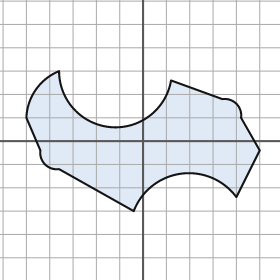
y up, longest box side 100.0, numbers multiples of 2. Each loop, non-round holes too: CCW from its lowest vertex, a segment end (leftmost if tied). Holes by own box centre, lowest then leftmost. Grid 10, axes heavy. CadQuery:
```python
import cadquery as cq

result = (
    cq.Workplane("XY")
    .moveTo(-4.0, -30.0)
    .threePointArc((16.0, -14.0), (40.0, -24.0))
    .lineTo(50.0, -4.0)
    .lineTo(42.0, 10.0)
    .threePointArc((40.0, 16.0), (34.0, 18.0))
    .lineTo(12.0, 26.0)
    .threePointArc((-14.0, 6.0), (-36.0, 30.0))
    .threePointArc((-46.0, 22.0), (-50.0, 10.0))
    .lineTo(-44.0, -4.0)
    .threePointArc((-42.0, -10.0), (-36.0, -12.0))
    .close()
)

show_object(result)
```